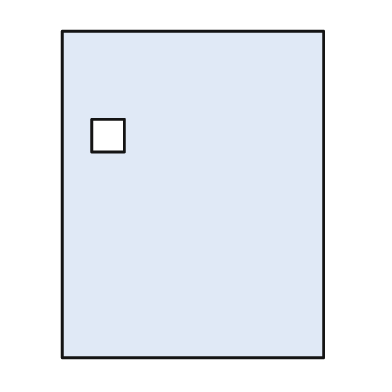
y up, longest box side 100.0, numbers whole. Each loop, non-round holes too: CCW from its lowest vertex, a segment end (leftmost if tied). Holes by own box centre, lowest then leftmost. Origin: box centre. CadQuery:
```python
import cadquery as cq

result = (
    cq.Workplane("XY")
    .moveTo(-40.0, -50.0)
    .lineTo(40.0, -50.0)
    .lineTo(40.0, 50.0)
    .lineTo(-40.0, 50.0)
    .close()
    .moveTo(-31.0, 13.0)
    .lineTo(-21.0, 13.0)
    .lineTo(-21.0, 23.0)
    .lineTo(-31.0, 23.0)
    .close()
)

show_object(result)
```